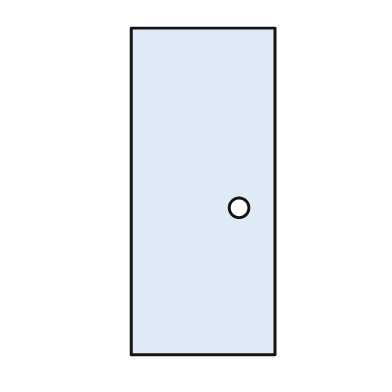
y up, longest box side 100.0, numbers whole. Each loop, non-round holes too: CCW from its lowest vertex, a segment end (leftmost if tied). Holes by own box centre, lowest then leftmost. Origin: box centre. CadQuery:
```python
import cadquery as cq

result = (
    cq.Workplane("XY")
    .moveTo(-22.0, -50.0)
    .lineTo(22.0, -50.0)
    .lineTo(22.0, 50.0)
    .lineTo(-22.0, 50.0)
    .close()
    .moveTo(11.0, -5.0)
    .circle(3.0)
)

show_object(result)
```